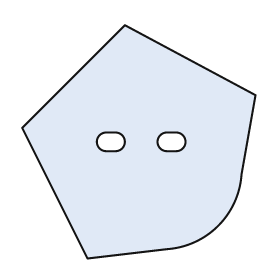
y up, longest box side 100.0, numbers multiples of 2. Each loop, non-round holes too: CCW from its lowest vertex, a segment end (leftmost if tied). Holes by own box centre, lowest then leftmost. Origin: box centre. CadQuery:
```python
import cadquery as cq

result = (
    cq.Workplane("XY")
    .moveTo(-22.0, -50.0)
    .lineTo(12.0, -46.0)
    .threePointArc((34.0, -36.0), (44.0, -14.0))
    .lineTo(50.0, 20.0)
    .lineTo(-6.0, 50.0)
    .lineTo(-50.0, 6.0)
    .close()
    .moveTo(-14.0, -4.0)
    .lineTo(-10.0, -4.0)
    .threePointArc((-6.0, 0.0), (-10.0, 4.0))
    .lineTo(-14.0, 4.0)
    .threePointArc((-18.0, 0.0), (-14.0, -4.0))
    .close()
    .moveTo(12.0, -4.0)
    .lineTo(16.0, -4.0)
    .threePointArc((20.0, 0.0), (16.0, 4.0))
    .lineTo(12.0, 4.0)
    .threePointArc((8.0, 0.0), (12.0, -4.0))
    .close()
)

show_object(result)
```